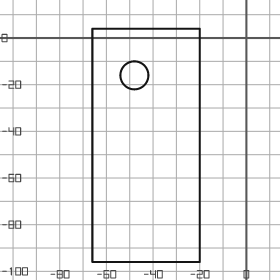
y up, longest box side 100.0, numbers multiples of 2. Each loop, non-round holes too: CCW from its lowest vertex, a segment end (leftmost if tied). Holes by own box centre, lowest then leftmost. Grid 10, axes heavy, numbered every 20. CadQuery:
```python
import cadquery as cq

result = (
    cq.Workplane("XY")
    .moveTo(-66.0, -96.0)
    .lineTo(-20.0, -96.0)
    .lineTo(-20.0, 4.0)
    .lineTo(-66.0, 4.0)
    .close()
    .moveTo(-48.0, -16.0)
    .circle(6.0)
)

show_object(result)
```